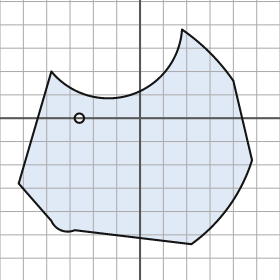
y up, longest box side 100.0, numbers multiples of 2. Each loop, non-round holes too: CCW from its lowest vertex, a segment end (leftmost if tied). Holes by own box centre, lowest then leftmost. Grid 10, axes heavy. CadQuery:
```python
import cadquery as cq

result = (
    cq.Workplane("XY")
    .moveTo(22.0, -54.0)
    .threePointArc((38.0, -38.0), (48.0, -18.0))
    .lineTo(40.0, 16.0)
    .threePointArc((30.0, 28.0), (18.0, 38.0))
    .threePointArc((-4.0, 10.0), (-38.0, 20.0))
    .lineTo(-52.0, -28.0)
    .lineTo(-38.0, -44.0)
    .threePointArc((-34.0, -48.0), (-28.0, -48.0))
    .close()
    .moveTo(-26.0, 0.0)
    .circle(2.0)
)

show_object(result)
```